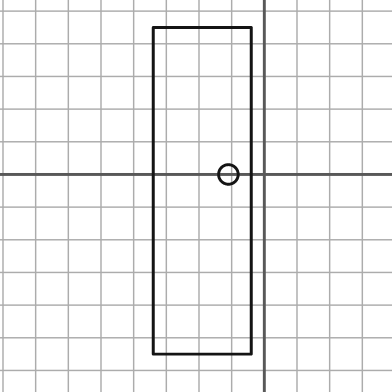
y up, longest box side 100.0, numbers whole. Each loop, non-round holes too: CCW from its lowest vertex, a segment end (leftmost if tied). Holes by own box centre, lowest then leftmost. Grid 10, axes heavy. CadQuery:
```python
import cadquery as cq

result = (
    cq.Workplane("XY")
    .moveTo(-34.0, -55.0)
    .lineTo(-4.0, -55.0)
    .lineTo(-4.0, 45.0)
    .lineTo(-34.0, 45.0)
    .close()
    .moveTo(-11.0, 0.0)
    .circle(3.0)
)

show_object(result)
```